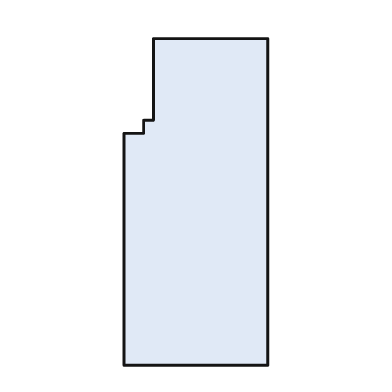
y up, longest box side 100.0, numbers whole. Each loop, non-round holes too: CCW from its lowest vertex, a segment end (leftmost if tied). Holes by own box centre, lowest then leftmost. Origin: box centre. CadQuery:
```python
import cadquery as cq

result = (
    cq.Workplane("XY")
    .moveTo(-22.0, -50.0)
    .lineTo(22.0, -50.0)
    .lineTo(22.0, 50.0)
    .lineTo(-13.0, 50.0)
    .lineTo(-13.0, 25.0)
    .lineTo(-16.0, 25.0)
    .lineTo(-16.0, 21.0)
    .lineTo(-22.0, 21.0)
    .close()
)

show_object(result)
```